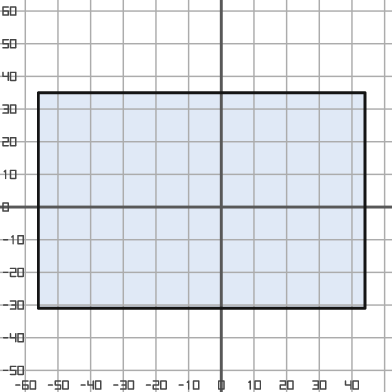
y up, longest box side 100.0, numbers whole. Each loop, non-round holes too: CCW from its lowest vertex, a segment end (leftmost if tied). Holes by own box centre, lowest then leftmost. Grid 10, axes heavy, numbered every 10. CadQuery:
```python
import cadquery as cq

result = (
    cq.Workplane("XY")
    .moveTo(-56.0, -31.0)
    .lineTo(44.0, -31.0)
    .lineTo(44.0, 35.0)
    .lineTo(-56.0, 35.0)
    .close()
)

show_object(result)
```